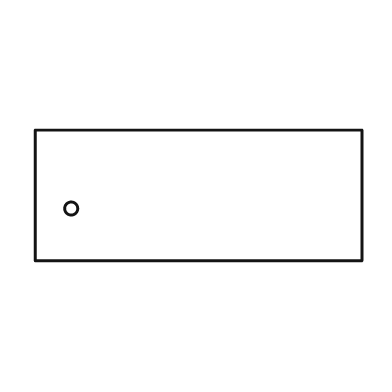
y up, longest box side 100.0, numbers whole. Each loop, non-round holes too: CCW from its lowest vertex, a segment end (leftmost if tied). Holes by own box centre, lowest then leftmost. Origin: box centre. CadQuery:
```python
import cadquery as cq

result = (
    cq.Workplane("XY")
    .moveTo(-50.0, -20.0)
    .lineTo(50.0, -20.0)
    .lineTo(50.0, 20.0)
    .lineTo(-50.0, 20.0)
    .close()
    .moveTo(-39.0, -4.0)
    .circle(2.0)
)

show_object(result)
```